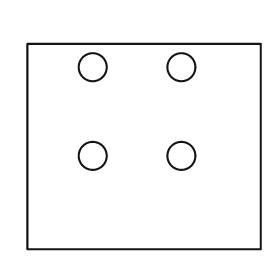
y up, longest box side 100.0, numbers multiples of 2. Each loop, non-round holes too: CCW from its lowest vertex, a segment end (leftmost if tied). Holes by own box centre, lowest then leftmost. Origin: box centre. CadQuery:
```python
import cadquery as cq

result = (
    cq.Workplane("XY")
    .moveTo(-50.0, -44.0)
    .lineTo(50.0, -44.0)
    .lineTo(50.0, 44.0)
    .lineTo(-50.0, 44.0)
    .close()
    .moveTo(-22.0, -4.0)
    .circle(6.0)
    .moveTo(16.0, -4.0)
    .circle(6.0)
    .moveTo(-22.0, 34.0)
    .circle(6.0)
    .moveTo(16.0, 34.0)
    .circle(6.0)
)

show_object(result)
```